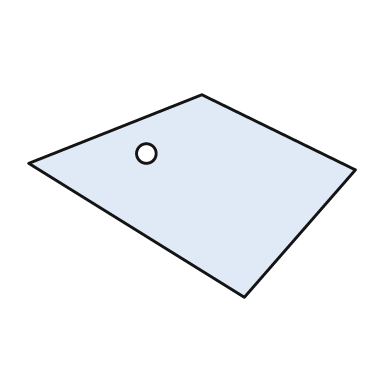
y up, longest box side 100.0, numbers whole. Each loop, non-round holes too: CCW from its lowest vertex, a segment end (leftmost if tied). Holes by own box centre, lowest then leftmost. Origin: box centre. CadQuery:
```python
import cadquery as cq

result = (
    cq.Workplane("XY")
    .moveTo(16.0, -31.0)
    .lineTo(50.0, 8.0)
    .lineTo(3.0, 31.0)
    .lineTo(-50.0, 10.0)
    .close()
    .moveTo(-14.0, 13.0)
    .circle(3.0)
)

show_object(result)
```